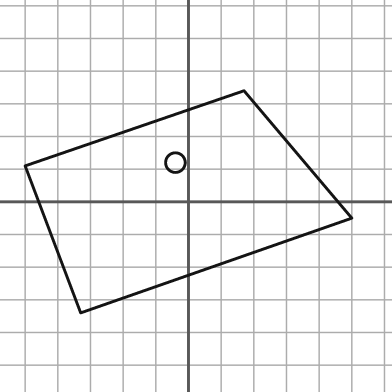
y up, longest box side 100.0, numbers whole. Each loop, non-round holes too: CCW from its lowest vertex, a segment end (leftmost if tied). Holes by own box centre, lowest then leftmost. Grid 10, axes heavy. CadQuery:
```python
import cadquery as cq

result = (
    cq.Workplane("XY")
    .moveTo(-33.0, -34.0)
    .lineTo(50.0, -5.0)
    .lineTo(17.0, 34.0)
    .lineTo(-50.0, 11.0)
    .close()
    .moveTo(-4.0, 12.0)
    .circle(3.0)
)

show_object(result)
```